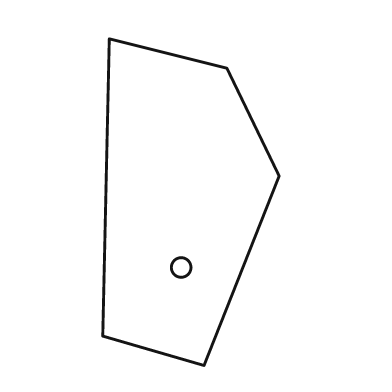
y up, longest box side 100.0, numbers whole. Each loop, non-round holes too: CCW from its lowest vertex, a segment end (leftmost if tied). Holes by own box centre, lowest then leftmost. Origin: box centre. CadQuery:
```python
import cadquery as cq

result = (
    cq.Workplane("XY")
    .moveTo(4.0, -50.0)
    .lineTo(27.0, 8.0)
    .lineTo(11.0, 41.0)
    .lineTo(-25.0, 50.0)
    .lineTo(-27.0, -41.0)
    .close()
    .moveTo(-3.0, -20.0)
    .circle(3.0)
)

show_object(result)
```